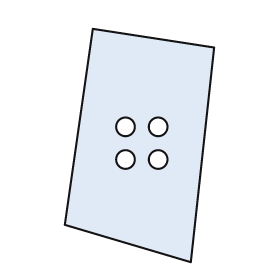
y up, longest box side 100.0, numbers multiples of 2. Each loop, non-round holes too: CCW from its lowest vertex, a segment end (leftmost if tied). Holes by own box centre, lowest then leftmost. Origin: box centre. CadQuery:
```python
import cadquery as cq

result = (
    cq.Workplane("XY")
    .moveTo(22.0, -50.0)
    .lineTo(32.0, 42.0)
    .lineTo(-20.0, 50.0)
    .lineTo(-32.0, -34.0)
    .close()
    .moveTo(-6.0, -6.0)
    .circle(4.0)
    .moveTo(8.0, -6.0)
    .circle(4.0)
    .moveTo(-6.0, 8.0)
    .circle(4.0)
    .moveTo(8.0, 8.0)
    .circle(4.0)
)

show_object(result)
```